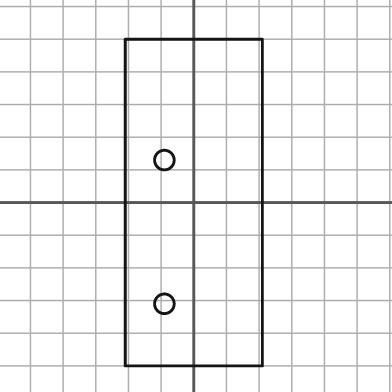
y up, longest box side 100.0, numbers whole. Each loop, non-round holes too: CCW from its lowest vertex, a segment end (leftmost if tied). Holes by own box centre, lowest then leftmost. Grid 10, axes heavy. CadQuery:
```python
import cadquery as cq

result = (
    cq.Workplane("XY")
    .moveTo(-21.0, -50.0)
    .lineTo(21.0, -50.0)
    .lineTo(21.0, 50.0)
    .lineTo(-21.0, 50.0)
    .close()
    .moveTo(-9.0, -31.0)
    .circle(3.0)
    .moveTo(-9.0, 13.0)
    .circle(3.0)
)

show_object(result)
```